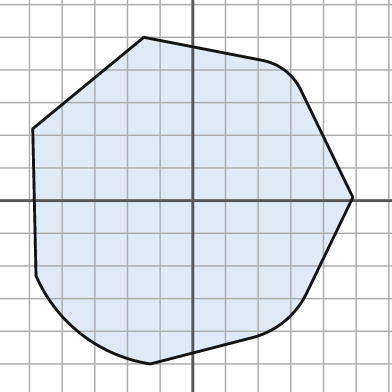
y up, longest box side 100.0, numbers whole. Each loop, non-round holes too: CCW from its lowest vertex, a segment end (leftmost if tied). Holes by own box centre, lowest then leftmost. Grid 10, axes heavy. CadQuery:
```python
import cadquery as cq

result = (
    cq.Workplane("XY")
    .moveTo(-13.0, -50.0)
    .lineTo(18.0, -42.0)
    .threePointArc((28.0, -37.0), (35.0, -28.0))
    .lineTo(49.0, 1.0)
    .lineTo(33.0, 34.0)
    .threePointArc((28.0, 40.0), (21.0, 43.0))
    .lineTo(-15.0, 50.0)
    .lineTo(-49.0, 22.0)
    .lineTo(-48.0, -23.0)
    .threePointArc((-34.0, -41.0), (-13.0, -50.0))
    .close()
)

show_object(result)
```